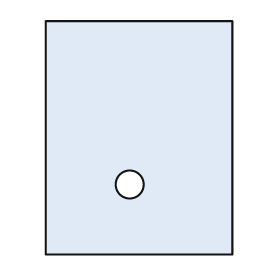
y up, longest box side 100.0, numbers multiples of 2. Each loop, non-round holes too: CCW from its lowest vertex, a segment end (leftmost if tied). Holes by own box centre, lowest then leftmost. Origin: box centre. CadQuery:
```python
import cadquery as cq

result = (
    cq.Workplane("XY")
    .moveTo(-40.0, -50.0)
    .lineTo(40.0, -50.0)
    .lineTo(40.0, 50.0)
    .lineTo(-40.0, 50.0)
    .close()
    .moveTo(-4.0, -20.0)
    .circle(6.0)
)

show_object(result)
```